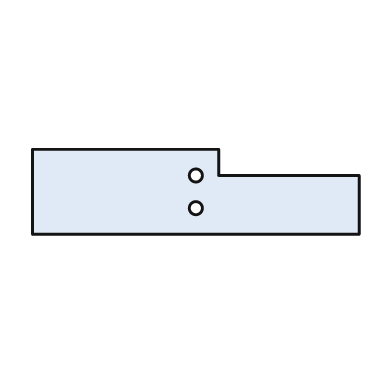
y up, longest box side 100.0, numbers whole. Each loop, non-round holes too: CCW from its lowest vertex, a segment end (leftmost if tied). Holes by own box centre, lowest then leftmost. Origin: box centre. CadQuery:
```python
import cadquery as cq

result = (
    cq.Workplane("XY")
    .moveTo(-50.0, -13.0)
    .lineTo(50.0, -13.0)
    .lineTo(50.0, 5.0)
    .lineTo(7.0, 5.0)
    .lineTo(7.0, 13.0)
    .lineTo(-50.0, 13.0)
    .close()
    .moveTo(0.0, -5.0)
    .circle(2.0)
    .moveTo(0.0, 5.0)
    .circle(2.0)
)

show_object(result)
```